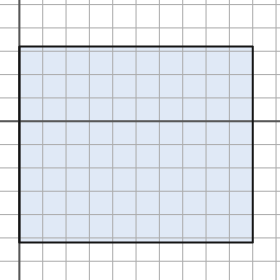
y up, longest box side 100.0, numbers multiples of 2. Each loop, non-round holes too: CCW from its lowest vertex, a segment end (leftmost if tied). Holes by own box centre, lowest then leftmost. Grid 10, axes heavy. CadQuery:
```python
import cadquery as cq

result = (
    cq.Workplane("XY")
    .moveTo(0.0, -52.0)
    .lineTo(100.0, -52.0)
    .lineTo(100.0, 32.0)
    .lineTo(0.0, 32.0)
    .close()
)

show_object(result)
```